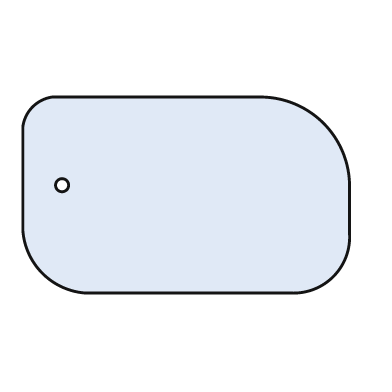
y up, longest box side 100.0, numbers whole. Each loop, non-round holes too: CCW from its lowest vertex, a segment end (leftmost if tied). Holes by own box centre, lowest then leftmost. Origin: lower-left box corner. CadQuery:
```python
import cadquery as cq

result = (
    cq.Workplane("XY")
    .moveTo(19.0, 0.0)
    .lineTo(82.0, 0.0)
    .threePointArc((95.0, 5.0), (100.0, 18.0))
    .lineTo(100.0, 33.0)
    .threePointArc((92.0, 52.0), (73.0, 60.0))
    .lineTo(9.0, 60.0)
    .threePointArc((3.0, 57.0), (0.0, 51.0))
    .lineTo(0.0, 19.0)
    .threePointArc((6.0, 6.0), (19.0, 0.0))
    .close()
    .moveTo(12.0, 33.0)
    .circle(2.0)
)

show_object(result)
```